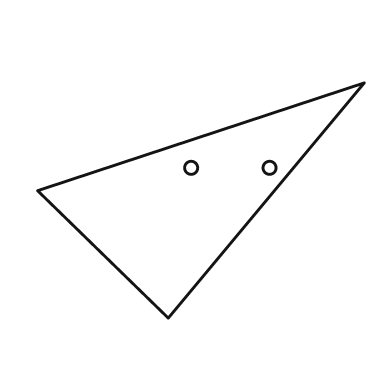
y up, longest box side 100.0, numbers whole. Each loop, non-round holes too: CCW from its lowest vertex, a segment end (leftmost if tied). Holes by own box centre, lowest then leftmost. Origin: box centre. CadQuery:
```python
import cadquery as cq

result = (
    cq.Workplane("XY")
    .moveTo(-10.0, -36.0)
    .lineTo(50.0, 36.0)
    .lineTo(-50.0, 3.0)
    .close()
    .moveTo(-3.0, 10.0)
    .circle(2.0)
    .moveTo(21.0, 10.0)
    .circle(2.0)
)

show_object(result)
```